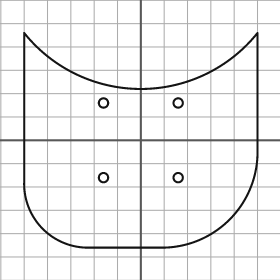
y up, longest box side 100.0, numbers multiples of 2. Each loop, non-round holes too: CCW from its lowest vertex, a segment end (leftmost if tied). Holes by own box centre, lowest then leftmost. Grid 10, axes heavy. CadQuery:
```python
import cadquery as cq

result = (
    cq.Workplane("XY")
    .moveTo(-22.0, -46.0)
    .lineTo(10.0, -46.0)
    .threePointArc((38.0, -34.0), (50.0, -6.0))
    .lineTo(50.0, 46.0)
    .threePointArc((0.0, 22.0), (-50.0, 46.0))
    .lineTo(-50.0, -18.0)
    .threePointArc((-42.0, -38.0), (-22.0, -46.0))
    .close()
    .moveTo(-16.0, -16.0)
    .circle(2.0)
    .moveTo(16.0, -16.0)
    .circle(2.0)
    .moveTo(-16.0, 16.0)
    .circle(2.0)
    .moveTo(16.0, 16.0)
    .circle(2.0)
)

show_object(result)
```